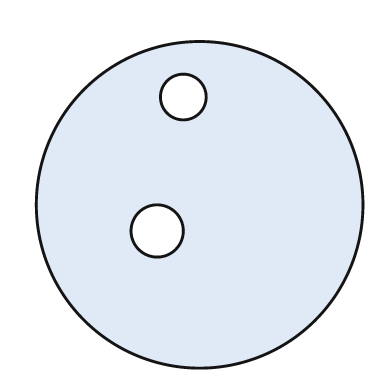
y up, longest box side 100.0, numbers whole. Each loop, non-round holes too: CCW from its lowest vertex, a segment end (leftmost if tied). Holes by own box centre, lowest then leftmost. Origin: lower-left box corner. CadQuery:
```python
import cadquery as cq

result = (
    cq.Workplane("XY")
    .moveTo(50.0, 50.0)
    .circle(50.0)
    .moveTo(37.0, 42.0)
    .circle(8.0)
    .moveTo(45.0, 83.0)
    .circle(7.0)
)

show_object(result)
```